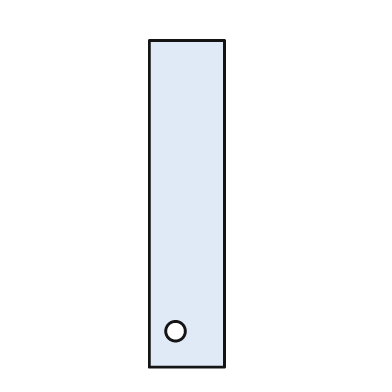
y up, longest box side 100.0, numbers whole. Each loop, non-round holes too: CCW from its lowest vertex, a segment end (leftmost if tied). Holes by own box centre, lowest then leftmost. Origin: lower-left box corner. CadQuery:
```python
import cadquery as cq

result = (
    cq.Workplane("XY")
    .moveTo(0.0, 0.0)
    .lineTo(23.0, 0.0)
    .lineTo(23.0, 100.0)
    .lineTo(0.0, 100.0)
    .close()
    .moveTo(8.0, 11.0)
    .circle(3.0)
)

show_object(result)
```